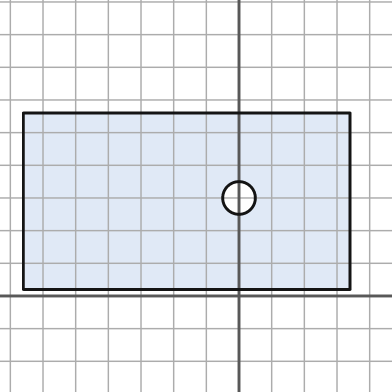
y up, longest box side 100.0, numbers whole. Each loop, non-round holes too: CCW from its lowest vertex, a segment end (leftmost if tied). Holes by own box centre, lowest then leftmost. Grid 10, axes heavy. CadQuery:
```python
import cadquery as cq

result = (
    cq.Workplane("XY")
    .moveTo(-66.0, 2.0)
    .lineTo(34.0, 2.0)
    .lineTo(34.0, 56.0)
    .lineTo(-66.0, 56.0)
    .close()
    .moveTo(0.0, 30.0)
    .circle(5.0)
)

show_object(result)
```